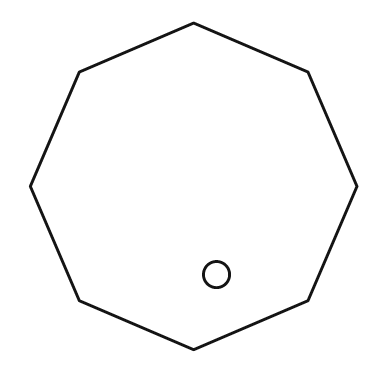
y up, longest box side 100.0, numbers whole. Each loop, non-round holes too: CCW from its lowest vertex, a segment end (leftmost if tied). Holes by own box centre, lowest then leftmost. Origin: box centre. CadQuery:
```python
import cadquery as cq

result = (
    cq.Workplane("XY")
    .moveTo(0.0, -50.0)
    .lineTo(35.0, -35.0)
    .lineTo(50.0, 0.0)
    .lineTo(35.0, 35.0)
    .lineTo(0.0, 50.0)
    .lineTo(-35.0, 35.0)
    .lineTo(-50.0, 0.0)
    .lineTo(-35.0, -35.0)
    .close()
    .moveTo(7.0, -27.0)
    .circle(4.0)
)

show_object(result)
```